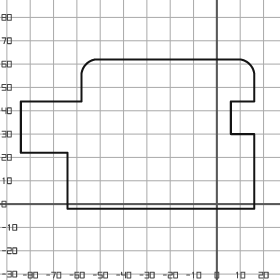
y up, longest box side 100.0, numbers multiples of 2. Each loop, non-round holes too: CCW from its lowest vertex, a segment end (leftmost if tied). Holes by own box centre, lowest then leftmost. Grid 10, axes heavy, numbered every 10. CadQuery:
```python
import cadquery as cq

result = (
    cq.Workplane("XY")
    .moveTo(-64.0, -2.0)
    .lineTo(16.0, -2.0)
    .lineTo(16.0, 30.0)
    .lineTo(6.0, 30.0)
    .lineTo(6.0, 44.0)
    .lineTo(16.0, 44.0)
    .lineTo(16.0, 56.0)
    .threePointArc((14.0, 60.0), (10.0, 62.0))
    .lineTo(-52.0, 62.0)
    .threePointArc((-56.0, 60.0), (-58.0, 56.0))
    .lineTo(-58.0, 44.0)
    .lineTo(-84.0, 44.0)
    .lineTo(-84.0, 22.0)
    .lineTo(-64.0, 22.0)
    .close()
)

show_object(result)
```